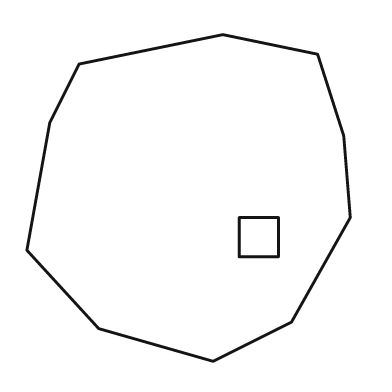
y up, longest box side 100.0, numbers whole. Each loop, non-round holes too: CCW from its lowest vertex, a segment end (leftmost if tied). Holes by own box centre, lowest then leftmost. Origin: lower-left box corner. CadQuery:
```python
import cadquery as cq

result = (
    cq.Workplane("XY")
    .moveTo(57.0, 0.0)
    .lineTo(81.0, 12.0)
    .lineTo(99.0, 44.0)
    .lineTo(97.0, 69.0)
    .lineTo(89.0, 94.0)
    .lineTo(60.0, 100.0)
    .lineTo(16.0, 91.0)
    .lineTo(7.0, 73.0)
    .lineTo(0.0, 34.0)
    .lineTo(22.0, 10.0)
    .close()
    .moveTo(65.0, 32.0)
    .lineTo(77.0, 32.0)
    .lineTo(77.0, 44.0)
    .lineTo(65.0, 44.0)
    .close()
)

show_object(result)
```